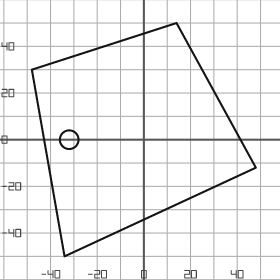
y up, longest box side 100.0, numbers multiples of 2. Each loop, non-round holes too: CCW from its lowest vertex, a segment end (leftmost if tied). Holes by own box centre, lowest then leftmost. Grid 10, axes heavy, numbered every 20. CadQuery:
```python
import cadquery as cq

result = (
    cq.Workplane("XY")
    .moveTo(-34.0, -50.0)
    .lineTo(48.0, -12.0)
    .lineTo(14.0, 50.0)
    .lineTo(-48.0, 30.0)
    .close()
    .moveTo(-32.0, 0.0)
    .circle(4.0)
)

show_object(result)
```